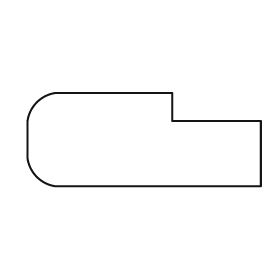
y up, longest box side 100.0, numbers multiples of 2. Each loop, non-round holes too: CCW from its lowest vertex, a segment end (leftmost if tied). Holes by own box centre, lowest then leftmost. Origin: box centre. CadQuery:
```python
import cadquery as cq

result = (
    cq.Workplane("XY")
    .moveTo(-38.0, -20.0)
    .lineTo(50.0, -20.0)
    .lineTo(50.0, 8.0)
    .lineTo(12.0, 8.0)
    .lineTo(12.0, 20.0)
    .lineTo(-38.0, 20.0)
    .threePointArc((-46.0, 16.0), (-50.0, 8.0))
    .lineTo(-50.0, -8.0)
    .threePointArc((-46.0, -16.0), (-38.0, -20.0))
    .close()
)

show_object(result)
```